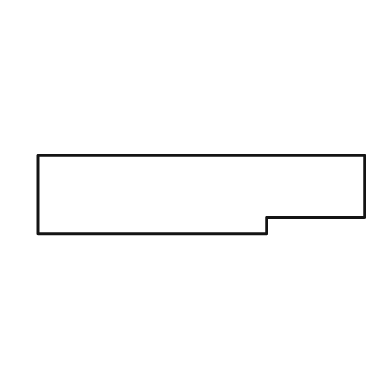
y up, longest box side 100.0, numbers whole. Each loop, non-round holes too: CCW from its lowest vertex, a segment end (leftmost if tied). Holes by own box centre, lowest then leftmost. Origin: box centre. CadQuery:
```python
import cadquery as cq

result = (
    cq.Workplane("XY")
    .moveTo(-50.0, -12.0)
    .lineTo(20.0, -12.0)
    .lineTo(20.0, -7.0)
    .lineTo(50.0, -7.0)
    .lineTo(50.0, 12.0)
    .lineTo(-50.0, 12.0)
    .close()
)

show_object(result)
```